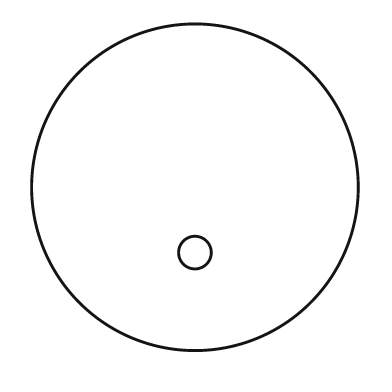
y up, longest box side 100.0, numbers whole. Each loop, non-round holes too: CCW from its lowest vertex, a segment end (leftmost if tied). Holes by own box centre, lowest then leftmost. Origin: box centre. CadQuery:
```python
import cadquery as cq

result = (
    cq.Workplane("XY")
    .moveTo(0.0, 0.0)
    .circle(50.0)
    .moveTo(0.0, -20.0)
    .circle(5.0)
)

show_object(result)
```